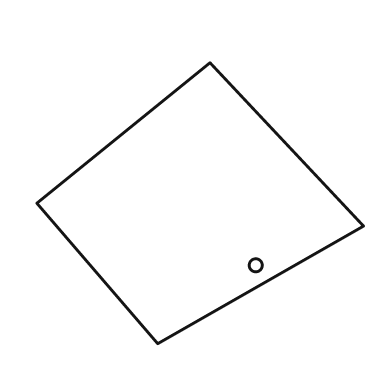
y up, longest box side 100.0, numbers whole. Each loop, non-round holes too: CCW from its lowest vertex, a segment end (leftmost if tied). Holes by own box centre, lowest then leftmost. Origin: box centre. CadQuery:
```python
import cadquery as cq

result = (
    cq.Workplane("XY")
    .moveTo(-13.0, -43.0)
    .lineTo(50.0, -7.0)
    .lineTo(3.0, 43.0)
    .lineTo(-50.0, 0.0)
    .close()
    .moveTo(17.0, -19.0)
    .circle(2.0)
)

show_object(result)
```